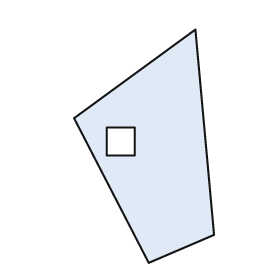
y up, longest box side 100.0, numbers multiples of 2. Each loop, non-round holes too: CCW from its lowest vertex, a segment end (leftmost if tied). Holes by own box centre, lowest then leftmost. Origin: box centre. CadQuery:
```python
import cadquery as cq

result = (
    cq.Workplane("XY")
    .moveTo(2.0, -50.0)
    .lineTo(30.0, -38.0)
    .lineTo(22.0, 50.0)
    .lineTo(-30.0, 12.0)
    .close()
    .moveTo(-16.0, -4.0)
    .lineTo(-4.0, -4.0)
    .lineTo(-4.0, 8.0)
    .lineTo(-16.0, 8.0)
    .close()
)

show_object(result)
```